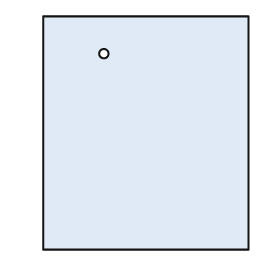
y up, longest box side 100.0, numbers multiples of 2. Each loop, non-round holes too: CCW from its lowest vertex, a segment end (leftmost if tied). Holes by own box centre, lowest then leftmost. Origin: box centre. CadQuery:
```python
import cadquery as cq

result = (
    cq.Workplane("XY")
    .moveTo(-44.0, -50.0)
    .lineTo(44.0, -50.0)
    .lineTo(44.0, 50.0)
    .lineTo(-44.0, 50.0)
    .close()
    .moveTo(-18.0, 34.0)
    .circle(2.0)
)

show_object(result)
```